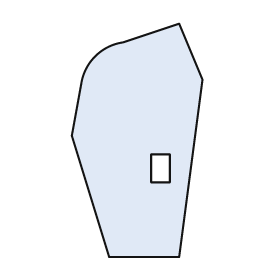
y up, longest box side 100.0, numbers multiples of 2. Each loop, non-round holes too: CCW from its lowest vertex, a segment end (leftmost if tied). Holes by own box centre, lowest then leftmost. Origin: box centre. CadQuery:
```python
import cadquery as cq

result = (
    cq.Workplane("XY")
    .moveTo(-12.0, -50.0)
    .lineTo(18.0, -50.0)
    .lineTo(28.0, 26.0)
    .lineTo(18.0, 50.0)
    .lineTo(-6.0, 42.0)
    .threePointArc((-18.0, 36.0), (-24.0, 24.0))
    .lineTo(-28.0, 2.0)
    .close()
    .moveTo(6.0, -18.0)
    .lineTo(14.0, -18.0)
    .lineTo(14.0, -6.0)
    .lineTo(6.0, -6.0)
    .close()
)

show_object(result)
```